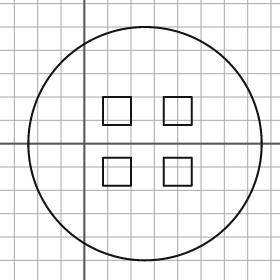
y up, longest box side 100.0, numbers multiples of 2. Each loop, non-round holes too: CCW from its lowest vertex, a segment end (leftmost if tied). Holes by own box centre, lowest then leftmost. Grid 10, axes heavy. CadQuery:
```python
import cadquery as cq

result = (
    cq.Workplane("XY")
    .moveTo(26.0, 0.0)
    .circle(50.0)
    .moveTo(8.0, -18.0)
    .lineTo(20.0, -18.0)
    .lineTo(20.0, -6.0)
    .lineTo(8.0, -6.0)
    .close()
    .moveTo(34.0, -18.0)
    .lineTo(46.0, -18.0)
    .lineTo(46.0, -6.0)
    .lineTo(34.0, -6.0)
    .close()
    .moveTo(8.0, 8.0)
    .lineTo(20.0, 8.0)
    .lineTo(20.0, 20.0)
    .lineTo(8.0, 20.0)
    .close()
    .moveTo(34.0, 8.0)
    .lineTo(46.0, 8.0)
    .lineTo(46.0, 20.0)
    .lineTo(34.0, 20.0)
    .close()
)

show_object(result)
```